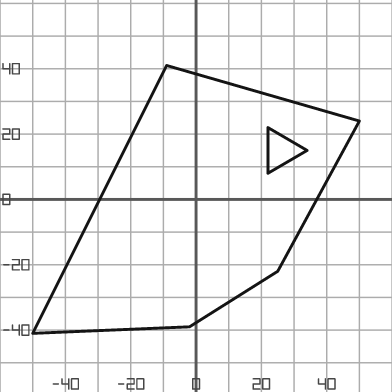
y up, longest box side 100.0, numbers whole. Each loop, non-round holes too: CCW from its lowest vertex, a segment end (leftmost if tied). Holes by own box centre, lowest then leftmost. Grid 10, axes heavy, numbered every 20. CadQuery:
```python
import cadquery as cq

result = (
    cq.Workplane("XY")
    .moveTo(-50.0, -41.0)
    .lineTo(-2.0, -39.0)
    .lineTo(25.0, -22.0)
    .lineTo(50.0, 24.0)
    .lineTo(-9.0, 41.0)
    .close()
    .moveTo(22.0, 8.0)
    .lineTo(34.0, 15.0)
    .lineTo(22.0, 22.0)
    .close()
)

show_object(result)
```